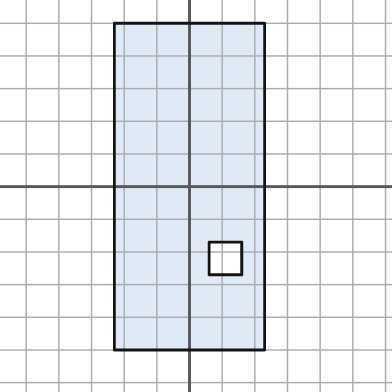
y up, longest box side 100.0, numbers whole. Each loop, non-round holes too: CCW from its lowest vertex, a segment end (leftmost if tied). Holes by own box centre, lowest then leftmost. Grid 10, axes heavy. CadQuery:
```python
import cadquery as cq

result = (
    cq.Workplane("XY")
    .moveTo(-23.0, -50.0)
    .lineTo(23.0, -50.0)
    .lineTo(23.0, 50.0)
    .lineTo(-23.0, 50.0)
    .close()
    .moveTo(6.0, -27.0)
    .lineTo(16.0, -27.0)
    .lineTo(16.0, -17.0)
    .lineTo(6.0, -17.0)
    .close()
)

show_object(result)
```